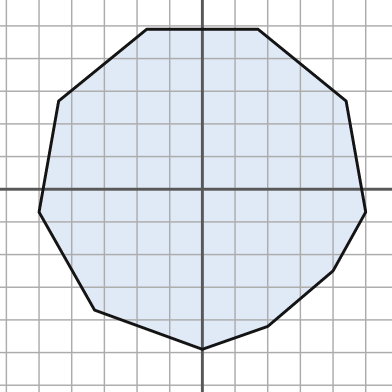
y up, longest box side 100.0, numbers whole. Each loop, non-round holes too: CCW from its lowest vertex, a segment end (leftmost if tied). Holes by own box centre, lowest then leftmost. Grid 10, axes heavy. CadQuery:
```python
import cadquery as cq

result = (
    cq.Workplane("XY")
    .moveTo(0.0, -49.0)
    .lineTo(20.0, -42.0)
    .lineTo(40.0, -25.0)
    .lineTo(50.0, -7.0)
    .lineTo(44.0, 27.0)
    .lineTo(17.0, 49.0)
    .lineTo(-17.0, 49.0)
    .lineTo(-44.0, 27.0)
    .lineTo(-50.0, -7.0)
    .lineTo(-33.0, -37.0)
    .close()
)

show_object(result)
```